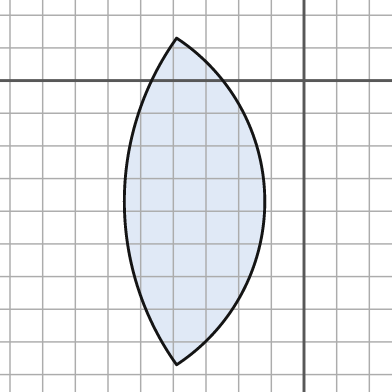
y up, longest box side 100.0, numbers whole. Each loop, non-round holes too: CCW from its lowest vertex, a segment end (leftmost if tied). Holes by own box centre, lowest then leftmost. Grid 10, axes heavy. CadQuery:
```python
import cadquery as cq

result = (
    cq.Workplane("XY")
    .moveTo(-39.0, -87.0)
    .threePointArc((-12.0, -37.0), (-39.0, 13.0))
    .threePointArc((-55.0, -37.0), (-39.0, -87.0))
    .close()
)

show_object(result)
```